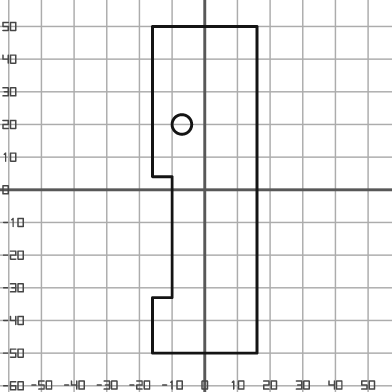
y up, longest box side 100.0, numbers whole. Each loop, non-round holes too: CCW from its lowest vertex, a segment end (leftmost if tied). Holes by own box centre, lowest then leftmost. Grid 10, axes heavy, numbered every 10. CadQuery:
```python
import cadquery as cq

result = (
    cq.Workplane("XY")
    .moveTo(-16.0, -50.0)
    .lineTo(16.0, -50.0)
    .lineTo(16.0, 50.0)
    .lineTo(-16.0, 50.0)
    .lineTo(-16.0, 4.0)
    .lineTo(-10.0, 4.0)
    .lineTo(-10.0, -33.0)
    .lineTo(-16.0, -33.0)
    .close()
    .moveTo(-7.0, 20.0)
    .circle(3.0)
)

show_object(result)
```